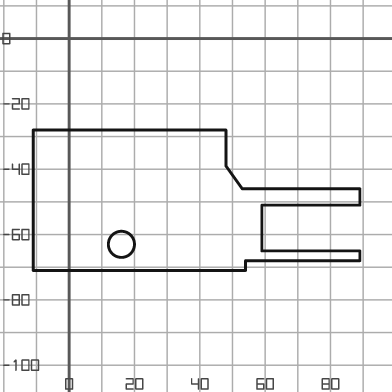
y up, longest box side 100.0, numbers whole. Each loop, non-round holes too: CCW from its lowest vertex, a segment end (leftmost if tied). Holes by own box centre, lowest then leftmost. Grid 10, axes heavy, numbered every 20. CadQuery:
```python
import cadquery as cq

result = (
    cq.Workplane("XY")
    .moveTo(-11.0, -71.0)
    .lineTo(54.0, -71.0)
    .lineTo(54.0, -68.0)
    .lineTo(89.0, -68.0)
    .lineTo(89.0, -65.0)
    .lineTo(59.0, -65.0)
    .lineTo(59.0, -51.0)
    .lineTo(89.0, -51.0)
    .lineTo(89.0, -46.0)
    .lineTo(53.0, -46.0)
    .lineTo(48.0, -39.0)
    .lineTo(48.0, -28.0)
    .lineTo(-11.0, -28.0)
    .close()
    .moveTo(16.0, -63.0)
    .circle(4.0)
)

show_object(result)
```